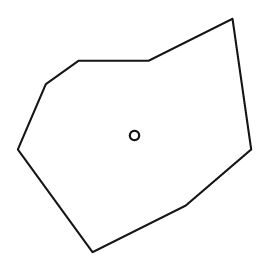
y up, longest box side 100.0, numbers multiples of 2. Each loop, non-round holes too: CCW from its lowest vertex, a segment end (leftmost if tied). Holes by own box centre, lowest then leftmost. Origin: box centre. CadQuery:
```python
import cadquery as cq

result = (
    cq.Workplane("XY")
    .moveTo(-18.0, -50.0)
    .lineTo(22.0, -30.0)
    .lineTo(50.0, -6.0)
    .lineTo(42.0, 50.0)
    .lineTo(6.0, 32.0)
    .lineTo(-24.0, 32.0)
    .lineTo(-38.0, 22.0)
    .lineTo(-50.0, -6.0)
    .close()
    .moveTo(0.0, 0.0)
    .circle(2.0)
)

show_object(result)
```